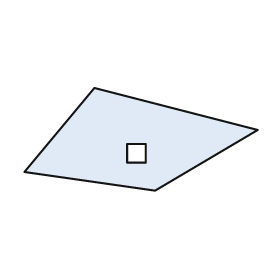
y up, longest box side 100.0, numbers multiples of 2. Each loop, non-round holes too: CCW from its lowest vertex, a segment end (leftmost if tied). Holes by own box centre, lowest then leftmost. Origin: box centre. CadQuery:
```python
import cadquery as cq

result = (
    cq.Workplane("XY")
    .moveTo(6.0, -22.0)
    .lineTo(50.0, 4.0)
    .lineTo(-20.0, 22.0)
    .lineTo(-50.0, -14.0)
    .close()
    .moveTo(-6.0, -10.0)
    .lineTo(2.0, -10.0)
    .lineTo(2.0, -2.0)
    .lineTo(-6.0, -2.0)
    .close()
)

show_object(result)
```